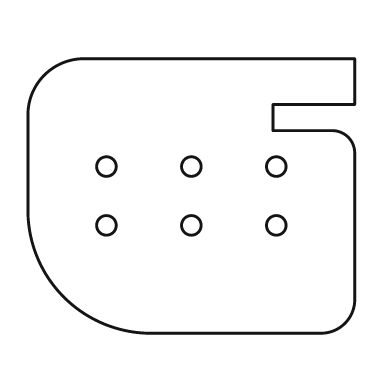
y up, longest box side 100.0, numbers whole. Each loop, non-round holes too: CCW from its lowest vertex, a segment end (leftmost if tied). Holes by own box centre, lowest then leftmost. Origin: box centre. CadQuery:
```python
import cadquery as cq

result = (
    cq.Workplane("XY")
    .moveTo(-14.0, -42.0)
    .lineTo(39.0, -42.0)
    .threePointArc((47.0, -39.0), (50.0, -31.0))
    .lineTo(50.0, 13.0)
    .threePointArc((48.0, 18.0), (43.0, 20.0))
    .lineTo(25.0, 20.0)
    .lineTo(25.0, 28.0)
    .lineTo(50.0, 28.0)
    .lineTo(50.0, 42.0)
    .lineTo(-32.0, 42.0)
    .threePointArc((-45.0, 37.0), (-50.0, 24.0))
    .lineTo(-50.0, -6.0)
    .threePointArc((-39.0, -31.0), (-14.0, -42.0))
    .close()
    .moveTo(-26.0, -9.0)
    .circle(3.0)
    .moveTo(0.0, -9.0)
    .circle(3.0)
    .moveTo(26.0, -9.0)
    .circle(3.0)
    .moveTo(-26.0, 9.0)
    .circle(3.0)
    .moveTo(0.0, 9.0)
    .circle(3.0)
    .moveTo(26.0, 9.0)
    .circle(3.0)
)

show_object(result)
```